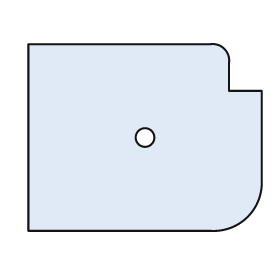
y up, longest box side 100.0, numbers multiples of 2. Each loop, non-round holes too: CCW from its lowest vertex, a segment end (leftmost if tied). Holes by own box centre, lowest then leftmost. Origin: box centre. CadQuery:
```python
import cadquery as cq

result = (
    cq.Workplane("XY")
    .moveTo(-50.0, -40.0)
    .lineTo(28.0, -40.0)
    .threePointArc((44.0, -34.0), (50.0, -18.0))
    .lineTo(50.0, 20.0)
    .lineTo(36.0, 20.0)
    .lineTo(36.0, 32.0)
    .threePointArc((34.0, 38.0), (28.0, 40.0))
    .lineTo(-50.0, 40.0)
    .close()
    .moveTo(0.0, 0.0)
    .circle(4.0)
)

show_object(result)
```